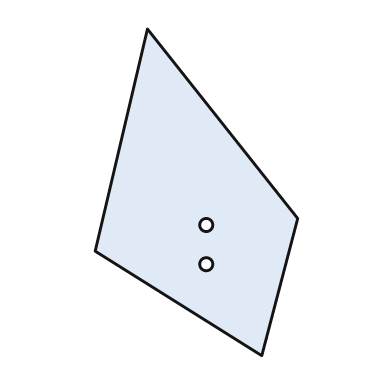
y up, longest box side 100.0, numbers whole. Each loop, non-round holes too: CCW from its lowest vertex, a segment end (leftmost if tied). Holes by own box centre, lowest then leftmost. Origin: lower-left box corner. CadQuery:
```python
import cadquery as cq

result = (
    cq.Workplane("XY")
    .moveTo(51.0, 0.0)
    .lineTo(62.0, 42.0)
    .lineTo(16.0, 100.0)
    .lineTo(0.0, 32.0)
    .close()
    .moveTo(34.0, 28.0)
    .circle(2.0)
    .moveTo(34.0, 40.0)
    .circle(2.0)
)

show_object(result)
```